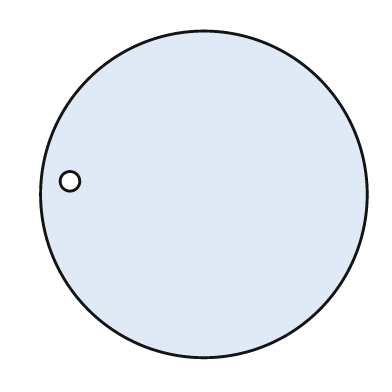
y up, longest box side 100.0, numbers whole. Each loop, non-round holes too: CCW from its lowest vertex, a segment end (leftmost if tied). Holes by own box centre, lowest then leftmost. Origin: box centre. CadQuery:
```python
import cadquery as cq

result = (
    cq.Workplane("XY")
    .moveTo(0.0, 0.0)
    .circle(50.0)
    .moveTo(-41.0, 4.0)
    .circle(3.0)
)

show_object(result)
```